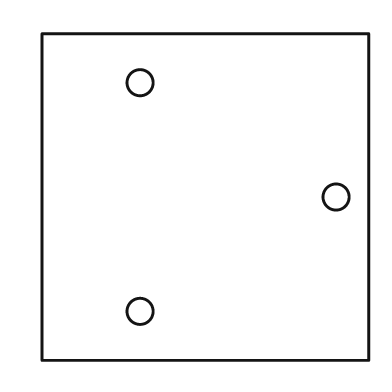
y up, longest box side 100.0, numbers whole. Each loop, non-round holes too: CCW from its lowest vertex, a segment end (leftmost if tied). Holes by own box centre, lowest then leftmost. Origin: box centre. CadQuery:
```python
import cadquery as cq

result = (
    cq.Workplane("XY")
    .moveTo(-50.0, -50.0)
    .lineTo(50.0, -50.0)
    .lineTo(50.0, 50.0)
    .lineTo(-50.0, 50.0)
    .close()
    .moveTo(-20.0, -35.0)
    .circle(4.0)
    .moveTo(40.0, 0.0)
    .circle(4.0)
    .moveTo(-20.0, 35.0)
    .circle(4.0)
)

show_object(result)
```